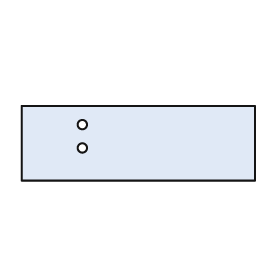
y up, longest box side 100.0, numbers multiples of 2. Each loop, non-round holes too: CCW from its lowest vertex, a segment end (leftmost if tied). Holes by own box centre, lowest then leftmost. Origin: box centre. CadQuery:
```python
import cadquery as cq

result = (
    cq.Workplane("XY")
    .moveTo(-50.0, -16.0)
    .lineTo(50.0, -16.0)
    .lineTo(50.0, 16.0)
    .lineTo(-50.0, 16.0)
    .close()
    .moveTo(-24.0, -2.0)
    .circle(2.0)
    .moveTo(-24.0, 8.0)
    .circle(2.0)
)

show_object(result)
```